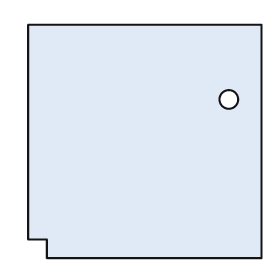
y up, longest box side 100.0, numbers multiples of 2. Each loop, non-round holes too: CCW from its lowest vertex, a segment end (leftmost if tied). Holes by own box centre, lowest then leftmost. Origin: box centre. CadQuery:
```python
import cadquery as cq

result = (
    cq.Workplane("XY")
    .moveTo(-42.0, -50.0)
    .lineTo(50.0, -50.0)
    .lineTo(50.0, 50.0)
    .lineTo(-50.0, 50.0)
    .lineTo(-50.0, -42.0)
    .lineTo(-42.0, -42.0)
    .close()
    .moveTo(36.0, 18.0)
    .circle(4.0)
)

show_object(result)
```